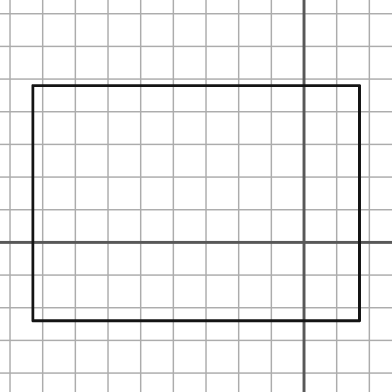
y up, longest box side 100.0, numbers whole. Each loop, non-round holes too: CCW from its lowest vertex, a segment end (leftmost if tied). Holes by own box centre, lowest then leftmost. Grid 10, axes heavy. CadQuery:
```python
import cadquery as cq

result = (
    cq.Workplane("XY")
    .moveTo(-83.0, -24.0)
    .lineTo(17.0, -24.0)
    .lineTo(17.0, 48.0)
    .lineTo(-83.0, 48.0)
    .close()
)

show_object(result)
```